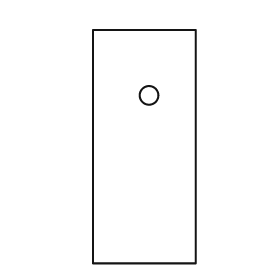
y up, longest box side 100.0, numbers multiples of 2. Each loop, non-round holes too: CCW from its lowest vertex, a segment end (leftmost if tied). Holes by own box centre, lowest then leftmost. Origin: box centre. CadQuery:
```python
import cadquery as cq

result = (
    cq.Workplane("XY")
    .moveTo(-22.0, -50.0)
    .lineTo(22.0, -50.0)
    .lineTo(22.0, 50.0)
    .lineTo(-22.0, 50.0)
    .close()
    .moveTo(2.0, 22.0)
    .circle(4.0)
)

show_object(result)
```